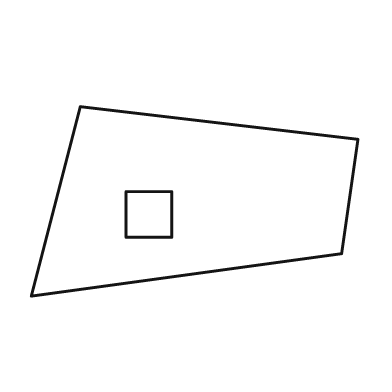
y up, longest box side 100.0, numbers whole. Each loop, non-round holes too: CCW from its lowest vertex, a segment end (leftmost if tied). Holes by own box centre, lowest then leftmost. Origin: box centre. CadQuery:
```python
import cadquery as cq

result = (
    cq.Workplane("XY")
    .moveTo(-50.0, -29.0)
    .lineTo(45.0, -16.0)
    .lineTo(50.0, 19.0)
    .lineTo(-35.0, 29.0)
    .close()
    .moveTo(-21.0, -11.0)
    .lineTo(-7.0, -11.0)
    .lineTo(-7.0, 3.0)
    .lineTo(-21.0, 3.0)
    .close()
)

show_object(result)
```